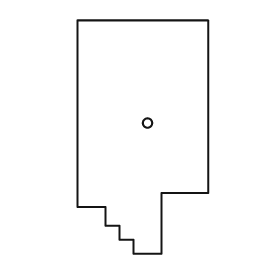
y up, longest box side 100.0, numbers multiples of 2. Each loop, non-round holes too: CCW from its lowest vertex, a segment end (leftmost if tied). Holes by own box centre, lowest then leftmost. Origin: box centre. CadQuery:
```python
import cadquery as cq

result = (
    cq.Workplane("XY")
    .moveTo(-4.0, -50.0)
    .lineTo(8.0, -50.0)
    .lineTo(8.0, -24.0)
    .lineTo(28.0, -24.0)
    .lineTo(28.0, 50.0)
    .lineTo(-28.0, 50.0)
    .lineTo(-28.0, -30.0)
    .lineTo(-16.0, -30.0)
    .lineTo(-16.0, -38.0)
    .lineTo(-10.0, -38.0)
    .lineTo(-10.0, -44.0)
    .lineTo(-4.0, -44.0)
    .close()
    .moveTo(2.0, 6.0)
    .circle(2.0)
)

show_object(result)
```